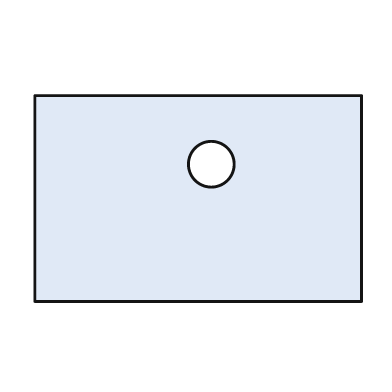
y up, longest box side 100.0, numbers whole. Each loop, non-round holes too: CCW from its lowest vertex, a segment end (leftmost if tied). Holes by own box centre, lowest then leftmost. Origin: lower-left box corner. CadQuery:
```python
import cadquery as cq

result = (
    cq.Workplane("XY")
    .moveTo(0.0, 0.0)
    .lineTo(100.0, 0.0)
    .lineTo(100.0, 63.0)
    .lineTo(0.0, 63.0)
    .close()
    .moveTo(54.0, 42.0)
    .circle(7.0)
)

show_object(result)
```